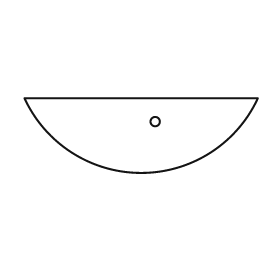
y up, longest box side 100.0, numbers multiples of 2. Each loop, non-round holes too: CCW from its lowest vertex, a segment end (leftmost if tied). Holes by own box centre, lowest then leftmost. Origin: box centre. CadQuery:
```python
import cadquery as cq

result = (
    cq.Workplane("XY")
    .moveTo(-50.0, 16.0)
    .threePointArc((0.0, -16.0), (50.0, 16.0))
    .close()
    .moveTo(6.0, 6.0)
    .circle(2.0)
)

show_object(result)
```